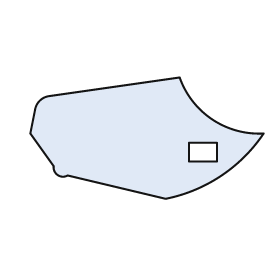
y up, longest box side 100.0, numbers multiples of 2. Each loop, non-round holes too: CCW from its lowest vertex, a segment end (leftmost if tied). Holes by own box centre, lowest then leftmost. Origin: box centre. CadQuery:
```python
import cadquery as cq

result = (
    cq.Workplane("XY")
    .moveTo(8.0, -26.0)
    .threePointArc((32.0, -16.0), (50.0, 2.0))
    .threePointArc((28.0, 8.0), (14.0, 26.0))
    .lineTo(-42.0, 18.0)
    .threePointArc((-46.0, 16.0), (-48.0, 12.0))
    .lineTo(-50.0, 2.0)
    .lineTo(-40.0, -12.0)
    .threePointArc((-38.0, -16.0), (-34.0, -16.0))
    .close()
    .moveTo(18.0, -10.0)
    .lineTo(30.0, -10.0)
    .lineTo(30.0, -2.0)
    .lineTo(18.0, -2.0)
    .close()
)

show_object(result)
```